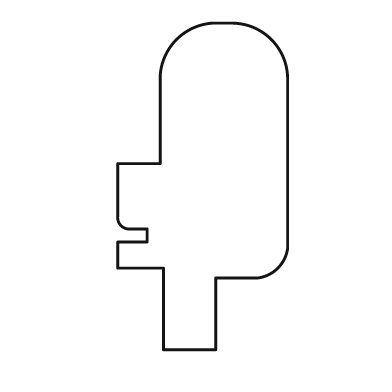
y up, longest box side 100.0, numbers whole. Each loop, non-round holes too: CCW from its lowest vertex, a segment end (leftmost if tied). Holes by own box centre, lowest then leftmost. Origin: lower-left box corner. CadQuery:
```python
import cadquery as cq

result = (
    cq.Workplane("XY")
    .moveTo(14.0, 0.0)
    .lineTo(30.0, 0.0)
    .lineTo(30.0, 22.0)
    .lineTo(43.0, 22.0)
    .threePointArc((49.0, 25.0), (52.0, 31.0))
    .lineTo(52.0, 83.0)
    .threePointArc((47.0, 95.0), (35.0, 100.0))
    .lineTo(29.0, 100.0)
    .threePointArc((18.0, 95.0), (13.0, 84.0))
    .lineTo(13.0, 57.0)
    .lineTo(0.0, 57.0)
    .lineTo(0.0, 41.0)
    .threePointArc((1.0, 38.0), (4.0, 37.0))
    .lineTo(9.0, 37.0)
    .lineTo(9.0, 33.0)
    .lineTo(0.0, 33.0)
    .lineTo(0.0, 25.0)
    .lineTo(14.0, 25.0)
    .close()
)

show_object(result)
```